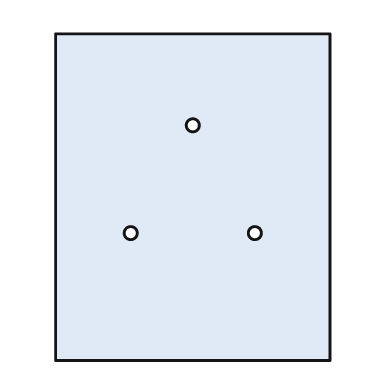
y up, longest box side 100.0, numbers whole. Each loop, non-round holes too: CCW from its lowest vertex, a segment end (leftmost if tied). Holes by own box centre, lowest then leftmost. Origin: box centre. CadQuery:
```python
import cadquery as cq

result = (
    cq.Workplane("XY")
    .moveTo(-42.0, -50.0)
    .lineTo(42.0, -50.0)
    .lineTo(42.0, 50.0)
    .lineTo(-42.0, 50.0)
    .close()
    .moveTo(-19.0, -11.0)
    .circle(2.0)
    .moveTo(19.0, -11.0)
    .circle(2.0)
    .moveTo(0.0, 22.0)
    .circle(2.0)
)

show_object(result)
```